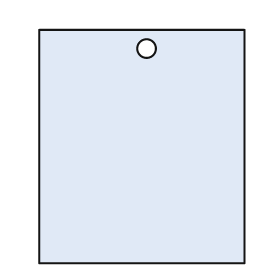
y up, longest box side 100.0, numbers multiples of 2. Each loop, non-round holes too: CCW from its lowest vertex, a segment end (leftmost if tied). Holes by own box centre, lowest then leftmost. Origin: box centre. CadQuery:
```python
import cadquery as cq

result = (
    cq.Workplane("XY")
    .moveTo(-44.0, -50.0)
    .lineTo(44.0, -50.0)
    .lineTo(44.0, 50.0)
    .lineTo(-44.0, 50.0)
    .close()
    .moveTo(2.0, 42.0)
    .circle(4.0)
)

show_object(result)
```